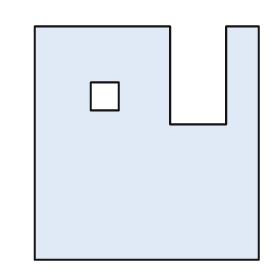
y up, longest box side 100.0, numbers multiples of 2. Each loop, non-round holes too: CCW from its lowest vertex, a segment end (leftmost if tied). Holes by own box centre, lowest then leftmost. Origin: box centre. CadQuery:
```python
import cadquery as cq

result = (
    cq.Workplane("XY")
    .moveTo(-48.0, -50.0)
    .lineTo(48.0, -50.0)
    .lineTo(48.0, 50.0)
    .lineTo(34.0, 50.0)
    .lineTo(34.0, 8.0)
    .lineTo(10.0, 8.0)
    .lineTo(10.0, 50.0)
    .lineTo(-48.0, 50.0)
    .close()
    .moveTo(-24.0, 14.0)
    .lineTo(-12.0, 14.0)
    .lineTo(-12.0, 26.0)
    .lineTo(-24.0, 26.0)
    .close()
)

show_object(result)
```